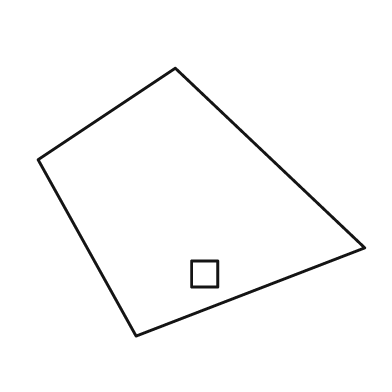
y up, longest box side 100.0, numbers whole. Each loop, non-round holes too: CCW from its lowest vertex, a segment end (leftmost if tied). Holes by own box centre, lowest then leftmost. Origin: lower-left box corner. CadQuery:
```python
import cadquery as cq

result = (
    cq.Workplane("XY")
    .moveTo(30.0, 0.0)
    .lineTo(100.0, 27.0)
    .lineTo(42.0, 82.0)
    .lineTo(0.0, 54.0)
    .close()
    .moveTo(47.0, 15.0)
    .lineTo(55.0, 15.0)
    .lineTo(55.0, 23.0)
    .lineTo(47.0, 23.0)
    .close()
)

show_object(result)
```